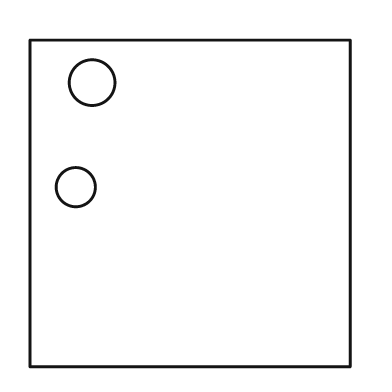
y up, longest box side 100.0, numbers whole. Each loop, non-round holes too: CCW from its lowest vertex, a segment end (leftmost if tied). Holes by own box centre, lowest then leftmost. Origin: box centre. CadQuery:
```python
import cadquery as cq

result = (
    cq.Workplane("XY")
    .moveTo(-49.0, -50.0)
    .lineTo(49.0, -50.0)
    .lineTo(49.0, 50.0)
    .lineTo(-49.0, 50.0)
    .close()
    .moveTo(-35.0, 5.0)
    .circle(6.0)
    .moveTo(-30.0, 37.0)
    .circle(7.0)
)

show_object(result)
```